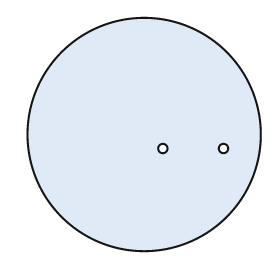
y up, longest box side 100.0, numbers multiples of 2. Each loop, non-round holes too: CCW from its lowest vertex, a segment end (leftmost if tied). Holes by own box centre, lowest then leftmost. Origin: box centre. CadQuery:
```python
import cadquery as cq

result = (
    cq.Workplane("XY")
    .moveTo(0.0, 0.0)
    .circle(50.0)
    .moveTo(8.0, -6.0)
    .circle(2.0)
    .moveTo(34.0, -6.0)
    .circle(2.0)
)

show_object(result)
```